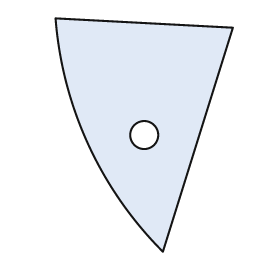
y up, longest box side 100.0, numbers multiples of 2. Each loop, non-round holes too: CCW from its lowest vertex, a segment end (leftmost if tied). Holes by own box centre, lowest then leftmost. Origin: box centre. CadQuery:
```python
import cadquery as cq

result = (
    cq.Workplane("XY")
    .moveTo(8.0, -50.0)
    .lineTo(38.0, 46.0)
    .lineTo(-38.0, 50.0)
    .threePointArc((-24.0, -4.0), (8.0, -50.0))
    .close()
    .moveTo(0.0, 0.0)
    .circle(6.0)
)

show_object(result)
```